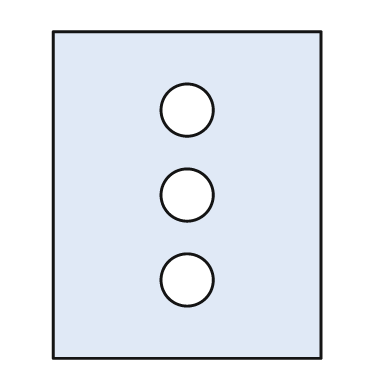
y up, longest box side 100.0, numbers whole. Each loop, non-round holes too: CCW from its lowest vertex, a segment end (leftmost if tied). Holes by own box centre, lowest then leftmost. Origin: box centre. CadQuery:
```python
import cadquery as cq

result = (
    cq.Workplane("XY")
    .moveTo(-41.0, -50.0)
    .lineTo(41.0, -50.0)
    .lineTo(41.0, 50.0)
    .lineTo(-41.0, 50.0)
    .close()
    .moveTo(0.0, -26.0)
    .circle(8.0)
    .moveTo(0.0, 0.0)
    .circle(8.0)
    .moveTo(0.0, 26.0)
    .circle(8.0)
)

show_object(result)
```